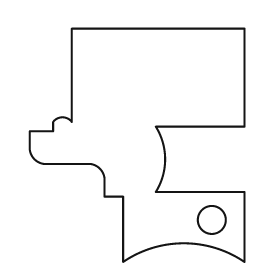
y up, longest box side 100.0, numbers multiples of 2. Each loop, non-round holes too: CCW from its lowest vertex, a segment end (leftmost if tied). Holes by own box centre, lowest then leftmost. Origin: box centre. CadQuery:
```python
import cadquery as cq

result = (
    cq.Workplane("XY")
    .moveTo(-6.0, -50.0)
    .threePointArc((20.0, -42.0), (46.0, -50.0))
    .lineTo(46.0, -20.0)
    .lineTo(8.0, -20.0)
    .threePointArc((12.0, -6.0), (8.0, 8.0))
    .lineTo(46.0, 8.0)
    .lineTo(46.0, 50.0)
    .lineTo(-28.0, 50.0)
    .lineTo(-28.0, 10.0)
    .threePointArc((-32.0, 12.0), (-36.0, 10.0))
    .lineTo(-36.0, 6.0)
    .lineTo(-46.0, 6.0)
    .lineTo(-46.0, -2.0)
    .threePointArc((-44.0, -6.0), (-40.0, -8.0))
    .lineTo(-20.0, -8.0)
    .threePointArc((-16.0, -10.0), (-14.0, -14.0))
    .lineTo(-14.0, -22.0)
    .lineTo(-6.0, -22.0)
    .close()
    .moveTo(32.0, -32.0)
    .circle(6.0)
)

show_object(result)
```